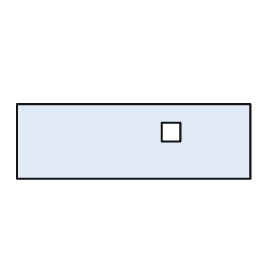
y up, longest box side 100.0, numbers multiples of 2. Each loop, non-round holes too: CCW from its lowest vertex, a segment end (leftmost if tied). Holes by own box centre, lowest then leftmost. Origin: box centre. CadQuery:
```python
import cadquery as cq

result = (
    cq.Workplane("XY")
    .moveTo(-50.0, -16.0)
    .lineTo(50.0, -16.0)
    .lineTo(50.0, 16.0)
    .lineTo(-50.0, 16.0)
    .close()
    .moveTo(12.0, 0.0)
    .lineTo(20.0, 0.0)
    .lineTo(20.0, 8.0)
    .lineTo(12.0, 8.0)
    .close()
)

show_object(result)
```